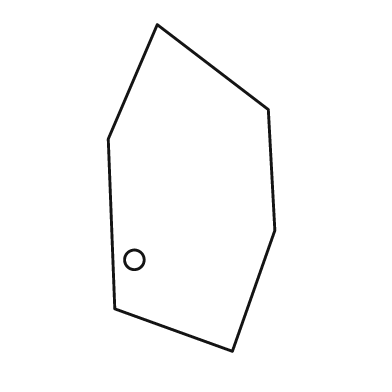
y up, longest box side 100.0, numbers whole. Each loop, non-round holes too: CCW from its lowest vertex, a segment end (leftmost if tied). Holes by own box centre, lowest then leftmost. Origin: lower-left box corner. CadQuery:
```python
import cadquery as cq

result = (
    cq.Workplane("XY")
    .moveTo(38.0, 0.0)
    .lineTo(51.0, 37.0)
    .lineTo(49.0, 74.0)
    .lineTo(15.0, 100.0)
    .lineTo(0.0, 65.0)
    .lineTo(2.0, 13.0)
    .close()
    .moveTo(8.0, 28.0)
    .circle(3.0)
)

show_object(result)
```